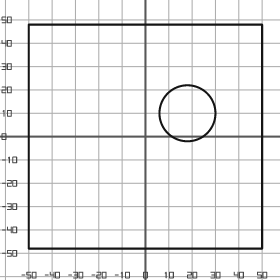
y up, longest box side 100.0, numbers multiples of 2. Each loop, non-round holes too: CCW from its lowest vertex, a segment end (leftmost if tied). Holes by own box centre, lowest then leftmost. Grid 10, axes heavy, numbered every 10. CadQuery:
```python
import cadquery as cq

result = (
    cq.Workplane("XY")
    .moveTo(-50.0, -48.0)
    .lineTo(50.0, -48.0)
    .lineTo(50.0, 48.0)
    .lineTo(-50.0, 48.0)
    .close()
    .moveTo(18.0, 10.0)
    .circle(12.0)
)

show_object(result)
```